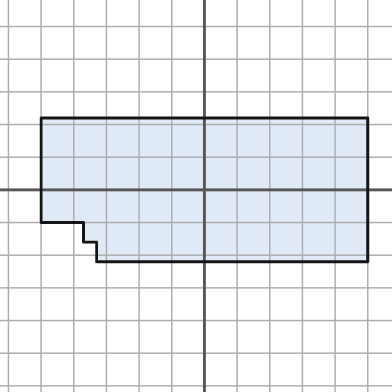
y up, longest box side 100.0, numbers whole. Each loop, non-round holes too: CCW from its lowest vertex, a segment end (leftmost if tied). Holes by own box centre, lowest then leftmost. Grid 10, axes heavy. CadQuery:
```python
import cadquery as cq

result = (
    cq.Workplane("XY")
    .moveTo(-33.0, -22.0)
    .lineTo(50.0, -22.0)
    .lineTo(50.0, 22.0)
    .lineTo(-50.0, 22.0)
    .lineTo(-50.0, -10.0)
    .lineTo(-37.0, -10.0)
    .lineTo(-37.0, -16.0)
    .lineTo(-33.0, -16.0)
    .close()
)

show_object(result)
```